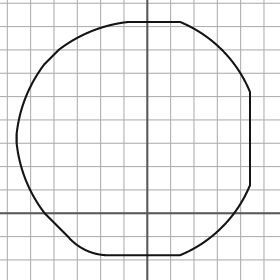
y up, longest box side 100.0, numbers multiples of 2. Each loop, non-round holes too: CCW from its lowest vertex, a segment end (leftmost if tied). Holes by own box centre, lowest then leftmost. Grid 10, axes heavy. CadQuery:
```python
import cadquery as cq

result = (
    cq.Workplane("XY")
    .moveTo(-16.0, -18.0)
    .lineTo(14.0, -18.0)
    .threePointArc((32.0, -6.0), (44.0, 12.0))
    .lineTo(44.0, 52.0)
    .threePointArc((32.0, 70.0), (14.0, 82.0))
    .lineTo(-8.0, 82.0)
    .threePointArc((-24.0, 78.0), (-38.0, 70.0))
    .lineTo(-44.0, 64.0)
    .threePointArc((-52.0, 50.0), (-56.0, 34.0))
    .lineTo(-56.0, 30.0)
    .threePointArc((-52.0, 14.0), (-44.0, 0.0))
    .lineTo(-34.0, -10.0)
    .threePointArc((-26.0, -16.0), (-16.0, -18.0))
    .close()
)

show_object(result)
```